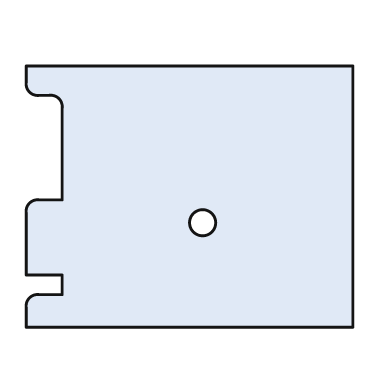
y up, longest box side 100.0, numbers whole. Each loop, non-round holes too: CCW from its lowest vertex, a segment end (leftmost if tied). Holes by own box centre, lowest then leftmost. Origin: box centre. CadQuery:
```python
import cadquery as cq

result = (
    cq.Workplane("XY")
    .moveTo(-50.0, -40.0)
    .lineTo(50.0, -40.0)
    .lineTo(50.0, 40.0)
    .lineTo(-50.0, 40.0)
    .lineTo(-50.0, 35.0)
    .threePointArc((-49.0, 32.0), (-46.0, 31.0))
    .lineTo(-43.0, 31.0)
    .threePointArc((-40.0, 30.0), (-39.0, 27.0))
    .lineTo(-39.0, -1.0)
    .lineTo(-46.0, -1.0)
    .threePointArc((-49.0, -2.0), (-50.0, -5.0))
    .lineTo(-50.0, -24.0)
    .lineTo(-39.0, -24.0)
    .lineTo(-39.0, -30.0)
    .lineTo(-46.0, -30.0)
    .threePointArc((-49.0, -31.0), (-50.0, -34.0))
    .close()
    .moveTo(4.0, -8.0)
    .circle(4.0)
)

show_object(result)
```